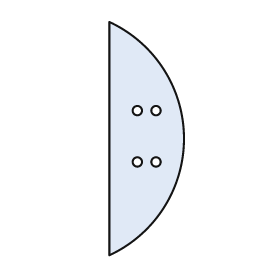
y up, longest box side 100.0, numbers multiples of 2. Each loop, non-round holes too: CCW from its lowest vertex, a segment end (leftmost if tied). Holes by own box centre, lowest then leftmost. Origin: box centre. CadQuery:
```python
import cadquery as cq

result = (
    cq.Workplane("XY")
    .moveTo(-16.0, -50.0)
    .threePointArc((16.0, 0.0), (-16.0, 50.0))
    .close()
    .moveTo(-4.0, -10.0)
    .circle(2.0)
    .moveTo(4.0, -10.0)
    .circle(2.0)
    .moveTo(-4.0, 12.0)
    .circle(2.0)
    .moveTo(4.0, 12.0)
    .circle(2.0)
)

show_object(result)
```